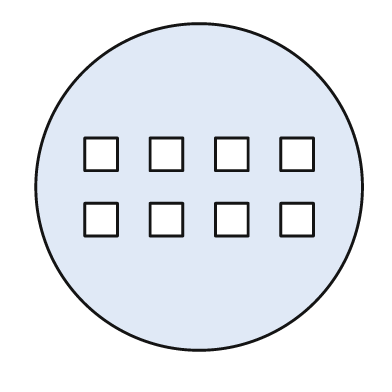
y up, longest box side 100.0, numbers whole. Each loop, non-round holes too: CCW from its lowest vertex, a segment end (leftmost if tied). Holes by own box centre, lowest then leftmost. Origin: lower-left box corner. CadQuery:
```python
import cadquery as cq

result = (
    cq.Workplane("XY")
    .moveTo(50.0, 50.0)
    .circle(50.0)
    .moveTo(15.0, 35.0)
    .lineTo(25.0, 35.0)
    .lineTo(25.0, 45.0)
    .lineTo(15.0, 45.0)
    .close()
    .moveTo(35.0, 35.0)
    .lineTo(45.0, 35.0)
    .lineTo(45.0, 45.0)
    .lineTo(35.0, 45.0)
    .close()
    .moveTo(55.0, 35.0)
    .lineTo(65.0, 35.0)
    .lineTo(65.0, 45.0)
    .lineTo(55.0, 45.0)
    .close()
    .moveTo(75.0, 35.0)
    .lineTo(85.0, 35.0)
    .lineTo(85.0, 45.0)
    .lineTo(75.0, 45.0)
    .close()
    .moveTo(15.0, 55.0)
    .lineTo(25.0, 55.0)
    .lineTo(25.0, 65.0)
    .lineTo(15.0, 65.0)
    .close()
    .moveTo(35.0, 55.0)
    .lineTo(45.0, 55.0)
    .lineTo(45.0, 65.0)
    .lineTo(35.0, 65.0)
    .close()
    .moveTo(55.0, 55.0)
    .lineTo(65.0, 55.0)
    .lineTo(65.0, 65.0)
    .lineTo(55.0, 65.0)
    .close()
    .moveTo(75.0, 55.0)
    .lineTo(85.0, 55.0)
    .lineTo(85.0, 65.0)
    .lineTo(75.0, 65.0)
    .close()
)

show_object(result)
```